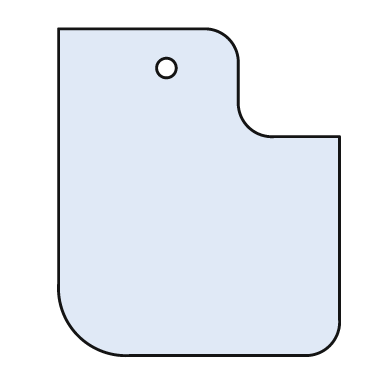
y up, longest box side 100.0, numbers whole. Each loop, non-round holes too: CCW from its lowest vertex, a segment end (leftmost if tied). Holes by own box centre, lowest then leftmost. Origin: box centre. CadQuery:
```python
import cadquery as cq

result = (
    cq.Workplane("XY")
    .moveTo(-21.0, -50.0)
    .lineTo(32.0, -50.0)
    .threePointArc((40.0, -47.0), (43.0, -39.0))
    .lineTo(43.0, 17.0)
    .lineTo(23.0, 17.0)
    .threePointArc((15.0, 20.0), (12.0, 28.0))
    .lineTo(12.0, 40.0)
    .threePointArc((9.0, 47.0), (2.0, 50.0))
    .lineTo(-43.0, 50.0)
    .lineTo(-43.0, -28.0)
    .threePointArc((-37.0, -44.0), (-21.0, -50.0))
    .close()
    .moveTo(-10.0, 38.0)
    .circle(3.0)
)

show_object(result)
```